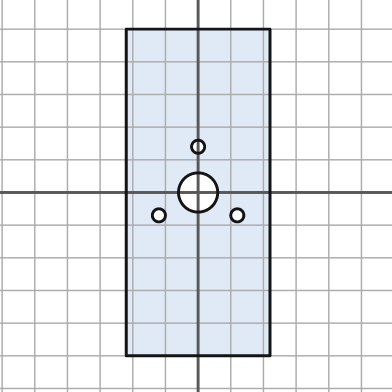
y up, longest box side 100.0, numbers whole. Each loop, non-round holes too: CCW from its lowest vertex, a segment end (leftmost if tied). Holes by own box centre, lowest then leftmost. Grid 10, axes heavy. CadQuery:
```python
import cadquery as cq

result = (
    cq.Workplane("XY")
    .moveTo(-22.0, -50.0)
    .lineTo(22.0, -50.0)
    .lineTo(22.0, 50.0)
    .lineTo(-22.0, 50.0)
    .close()
    .moveTo(-12.0, -7.0)
    .circle(2.0)
    .moveTo(12.0, -7.0)
    .circle(2.0)
    .moveTo(0.0, 0.0)
    .circle(6.0)
    .moveTo(0.0, 14.0)
    .circle(2.0)
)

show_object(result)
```